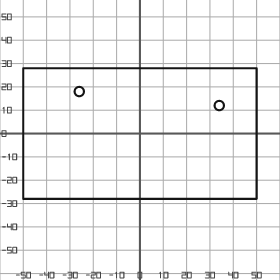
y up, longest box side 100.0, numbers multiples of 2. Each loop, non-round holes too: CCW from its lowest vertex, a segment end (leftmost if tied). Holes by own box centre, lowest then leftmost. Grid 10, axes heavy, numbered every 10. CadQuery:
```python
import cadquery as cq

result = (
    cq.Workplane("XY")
    .moveTo(-50.0, -28.0)
    .lineTo(50.0, -28.0)
    .lineTo(50.0, 28.0)
    .lineTo(-50.0, 28.0)
    .close()
    .moveTo(34.0, 12.0)
    .circle(2.0)
    .moveTo(-26.0, 18.0)
    .circle(2.0)
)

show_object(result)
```